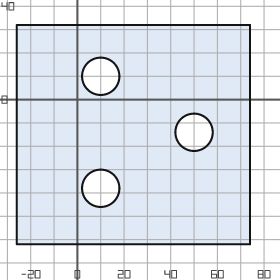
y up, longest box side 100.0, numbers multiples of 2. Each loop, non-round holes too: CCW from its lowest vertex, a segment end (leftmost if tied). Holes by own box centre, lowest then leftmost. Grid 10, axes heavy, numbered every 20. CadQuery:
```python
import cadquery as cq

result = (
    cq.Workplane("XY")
    .moveTo(-26.0, -62.0)
    .lineTo(74.0, -62.0)
    .lineTo(74.0, 32.0)
    .lineTo(-26.0, 32.0)
    .close()
    .moveTo(10.0, -38.0)
    .circle(8.0)
    .moveTo(50.0, -14.0)
    .circle(8.0)
    .moveTo(10.0, 10.0)
    .circle(8.0)
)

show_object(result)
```